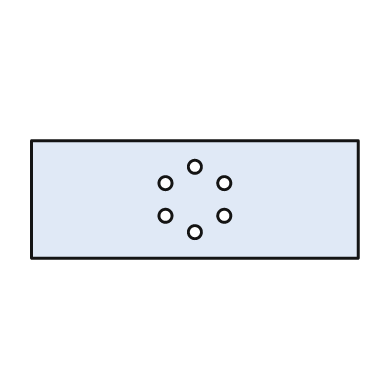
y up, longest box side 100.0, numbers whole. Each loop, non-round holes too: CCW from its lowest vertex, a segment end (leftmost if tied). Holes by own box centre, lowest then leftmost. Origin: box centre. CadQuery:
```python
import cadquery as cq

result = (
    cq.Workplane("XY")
    .moveTo(-50.0, -18.0)
    .lineTo(50.0, -18.0)
    .lineTo(50.0, 18.0)
    .lineTo(-50.0, 18.0)
    .close()
    .moveTo(0.0, -10.0)
    .circle(2.0)
    .moveTo(-9.0, -5.0)
    .circle(2.0)
    .moveTo(9.0, -5.0)
    .circle(2.0)
    .moveTo(-9.0, 5.0)
    .circle(2.0)
    .moveTo(9.0, 5.0)
    .circle(2.0)
    .moveTo(0.0, 10.0)
    .circle(2.0)
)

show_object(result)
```